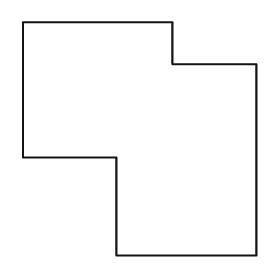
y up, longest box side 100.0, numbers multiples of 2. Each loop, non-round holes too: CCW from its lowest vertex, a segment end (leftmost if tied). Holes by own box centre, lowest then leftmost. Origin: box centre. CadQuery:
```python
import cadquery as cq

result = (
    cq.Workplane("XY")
    .moveTo(-10.0, -50.0)
    .lineTo(50.0, -50.0)
    .lineTo(50.0, 32.0)
    .lineTo(14.0, 32.0)
    .lineTo(14.0, 50.0)
    .lineTo(-50.0, 50.0)
    .lineTo(-50.0, -8.0)
    .lineTo(-10.0, -8.0)
    .close()
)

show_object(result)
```